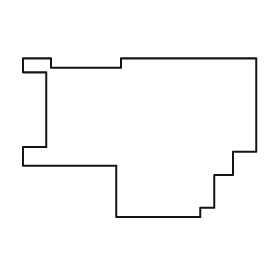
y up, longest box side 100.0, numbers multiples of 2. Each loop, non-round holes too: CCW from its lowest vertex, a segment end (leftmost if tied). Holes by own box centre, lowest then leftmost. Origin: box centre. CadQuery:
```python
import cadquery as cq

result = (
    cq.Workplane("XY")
    .moveTo(-10.0, -34.0)
    .lineTo(26.0, -34.0)
    .lineTo(26.0, -30.0)
    .lineTo(32.0, -30.0)
    .lineTo(32.0, -16.0)
    .lineTo(40.0, -16.0)
    .lineTo(40.0, -6.0)
    .lineTo(50.0, -6.0)
    .lineTo(50.0, 34.0)
    .lineTo(-8.0, 34.0)
    .lineTo(-8.0, 30.0)
    .lineTo(-38.0, 30.0)
    .lineTo(-38.0, 34.0)
    .lineTo(-50.0, 34.0)
    .lineTo(-50.0, 28.0)
    .lineTo(-40.0, 28.0)
    .lineTo(-40.0, -4.0)
    .lineTo(-50.0, -4.0)
    .lineTo(-50.0, -12.0)
    .lineTo(-10.0, -12.0)
    .close()
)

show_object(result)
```